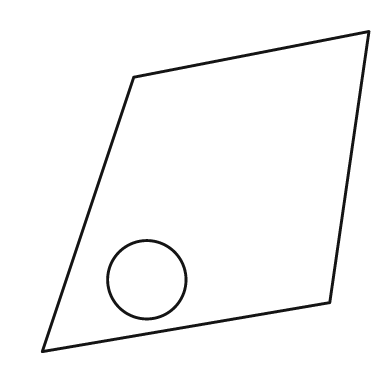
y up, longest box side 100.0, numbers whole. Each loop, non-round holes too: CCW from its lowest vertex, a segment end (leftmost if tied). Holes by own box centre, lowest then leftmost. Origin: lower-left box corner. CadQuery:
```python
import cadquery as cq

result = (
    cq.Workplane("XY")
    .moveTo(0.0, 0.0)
    .lineTo(88.0, 15.0)
    .lineTo(100.0, 98.0)
    .lineTo(28.0, 84.0)
    .close()
    .moveTo(32.0, 22.0)
    .circle(12.0)
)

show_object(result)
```